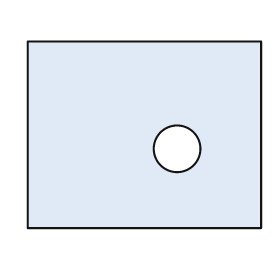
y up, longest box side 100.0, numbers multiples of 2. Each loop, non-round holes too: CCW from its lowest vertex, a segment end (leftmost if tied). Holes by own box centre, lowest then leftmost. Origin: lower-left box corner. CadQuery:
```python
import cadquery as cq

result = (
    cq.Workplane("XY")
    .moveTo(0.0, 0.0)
    .lineTo(100.0, 0.0)
    .lineTo(100.0, 80.0)
    .lineTo(0.0, 80.0)
    .close()
    .moveTo(64.0, 34.0)
    .circle(10.0)
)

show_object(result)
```